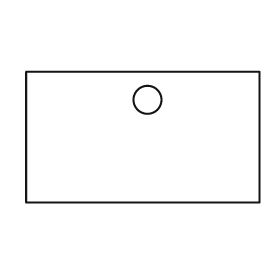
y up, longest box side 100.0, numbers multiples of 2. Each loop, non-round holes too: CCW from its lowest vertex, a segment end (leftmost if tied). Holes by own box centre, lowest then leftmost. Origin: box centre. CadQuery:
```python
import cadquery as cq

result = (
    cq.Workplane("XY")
    .moveTo(-50.0, -28.0)
    .lineTo(50.0, -28.0)
    .lineTo(50.0, 28.0)
    .lineTo(-50.0, 28.0)
    .close()
    .moveTo(2.0, 16.0)
    .circle(6.0)
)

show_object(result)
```